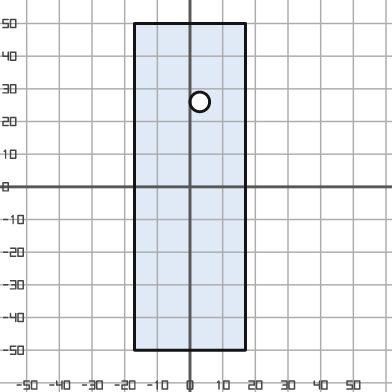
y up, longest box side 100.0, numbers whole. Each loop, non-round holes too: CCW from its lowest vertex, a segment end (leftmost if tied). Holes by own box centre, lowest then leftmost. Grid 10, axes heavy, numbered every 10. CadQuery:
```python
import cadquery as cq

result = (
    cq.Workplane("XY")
    .moveTo(-17.0, -50.0)
    .lineTo(17.0, -50.0)
    .lineTo(17.0, 50.0)
    .lineTo(-17.0, 50.0)
    .close()
    .moveTo(3.0, 26.0)
    .circle(3.0)
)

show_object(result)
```